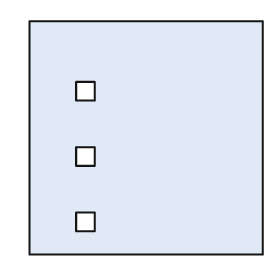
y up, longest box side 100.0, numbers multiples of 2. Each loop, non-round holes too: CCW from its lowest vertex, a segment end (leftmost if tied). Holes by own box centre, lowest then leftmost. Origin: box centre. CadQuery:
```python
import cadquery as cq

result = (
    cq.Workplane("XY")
    .moveTo(-50.0, -50.0)
    .lineTo(50.0, -50.0)
    .lineTo(50.0, 50.0)
    .lineTo(-50.0, 50.0)
    .close()
    .moveTo(-30.0, -40.0)
    .lineTo(-22.0, -40.0)
    .lineTo(-22.0, -32.0)
    .lineTo(-30.0, -32.0)
    .close()
    .moveTo(-30.0, -12.0)
    .lineTo(-22.0, -12.0)
    .lineTo(-22.0, -4.0)
    .lineTo(-30.0, -4.0)
    .close()
    .moveTo(-30.0, 16.0)
    .lineTo(-22.0, 16.0)
    .lineTo(-22.0, 24.0)
    .lineTo(-30.0, 24.0)
    .close()
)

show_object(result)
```